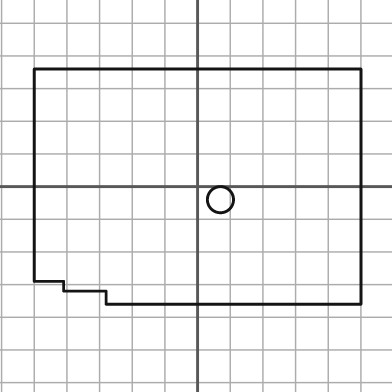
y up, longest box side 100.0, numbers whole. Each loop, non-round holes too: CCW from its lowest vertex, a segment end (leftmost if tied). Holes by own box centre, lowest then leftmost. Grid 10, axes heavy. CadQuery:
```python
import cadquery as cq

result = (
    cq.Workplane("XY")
    .moveTo(-28.0, -36.0)
    .lineTo(50.0, -36.0)
    .lineTo(50.0, 36.0)
    .lineTo(-50.0, 36.0)
    .lineTo(-50.0, -29.0)
    .lineTo(-41.0, -29.0)
    .lineTo(-41.0, -32.0)
    .lineTo(-28.0, -32.0)
    .close()
    .moveTo(7.0, -4.0)
    .circle(4.0)
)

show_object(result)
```